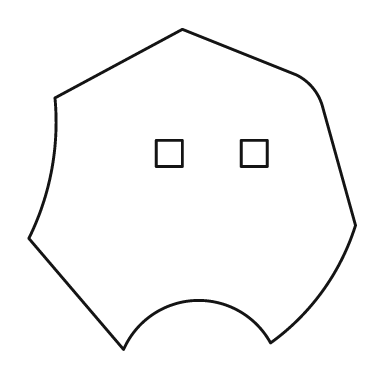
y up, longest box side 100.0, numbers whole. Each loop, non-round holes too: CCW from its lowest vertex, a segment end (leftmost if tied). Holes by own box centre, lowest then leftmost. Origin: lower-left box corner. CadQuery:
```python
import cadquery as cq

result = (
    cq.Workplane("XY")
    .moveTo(29.0, 0.0)
    .threePointArc((51.0, 15.0), (74.0, 2.0))
    .threePointArc((90.0, 18.0), (100.0, 38.0))
    .lineTo(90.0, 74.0)
    .threePointArc((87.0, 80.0), (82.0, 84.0))
    .lineTo(47.0, 98.0)
    .lineTo(8.0, 77.0)
    .threePointArc((7.0, 55.0), (0.0, 34.0))
    .close()
    .moveTo(39.0, 56.0)
    .lineTo(47.0, 56.0)
    .lineTo(47.0, 64.0)
    .lineTo(39.0, 64.0)
    .close()
    .moveTo(65.0, 56.0)
    .lineTo(73.0, 56.0)
    .lineTo(73.0, 64.0)
    .lineTo(65.0, 64.0)
    .close()
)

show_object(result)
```